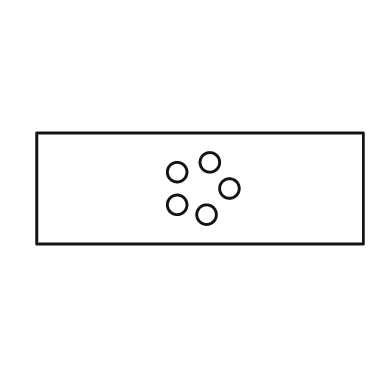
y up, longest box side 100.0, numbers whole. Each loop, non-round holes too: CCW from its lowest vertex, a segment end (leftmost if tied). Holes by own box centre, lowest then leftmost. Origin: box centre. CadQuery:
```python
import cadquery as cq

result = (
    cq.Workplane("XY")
    .moveTo(-50.0, -17.0)
    .lineTo(50.0, -17.0)
    .lineTo(50.0, 17.0)
    .lineTo(-50.0, 17.0)
    .close()
    .moveTo(2.0, -8.0)
    .circle(3.0)
    .moveTo(-7.0, -5.0)
    .circle(3.0)
    .moveTo(9.0, 0.0)
    .circle(3.0)
    .moveTo(-7.0, 5.0)
    .circle(3.0)
    .moveTo(3.0, 8.0)
    .circle(3.0)
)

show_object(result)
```